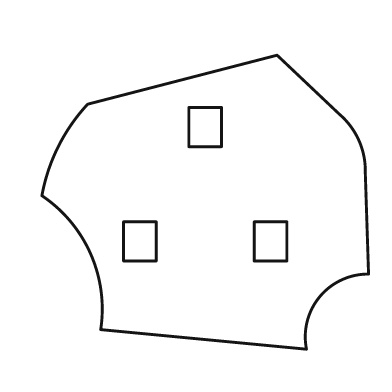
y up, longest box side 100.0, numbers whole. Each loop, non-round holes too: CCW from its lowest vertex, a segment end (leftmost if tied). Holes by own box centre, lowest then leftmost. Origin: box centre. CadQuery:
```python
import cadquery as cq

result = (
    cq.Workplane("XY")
    .moveTo(31.0, -45.0)
    .threePointArc((35.0, -29.0), (50.0, -22.0))
    .lineTo(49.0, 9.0)
    .threePointArc((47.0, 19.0), (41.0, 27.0))
    .lineTo(22.0, 45.0)
    .lineTo(-36.0, 30.0)
    .threePointArc((-45.0, 17.0), (-50.0, 2.0))
    .threePointArc((-35.0, -16.0), (-32.0, -39.0))
    .close()
    .moveTo(-25.0, -18.0)
    .lineTo(-15.0, -18.0)
    .lineTo(-15.0, -6.0)
    .lineTo(-25.0, -6.0)
    .close()
    .moveTo(15.0, -18.0)
    .lineTo(25.0, -18.0)
    .lineTo(25.0, -6.0)
    .lineTo(15.0, -6.0)
    .close()
    .moveTo(-5.0, 17.0)
    .lineTo(5.0, 17.0)
    .lineTo(5.0, 29.0)
    .lineTo(-5.0, 29.0)
    .close()
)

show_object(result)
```